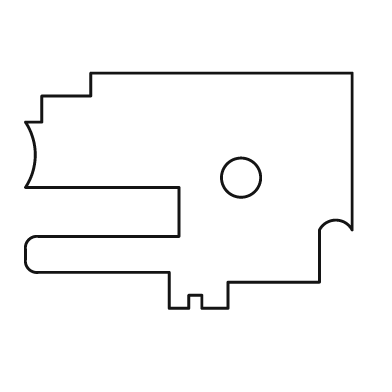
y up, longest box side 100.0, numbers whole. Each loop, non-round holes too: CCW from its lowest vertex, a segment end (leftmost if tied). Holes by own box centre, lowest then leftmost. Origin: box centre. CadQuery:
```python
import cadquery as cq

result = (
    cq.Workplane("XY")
    .moveTo(-6.0, -36.0)
    .lineTo(0.0, -36.0)
    .lineTo(0.0, -32.0)
    .lineTo(4.0, -32.0)
    .lineTo(4.0, -36.0)
    .lineTo(12.0, -36.0)
    .lineTo(12.0, -28.0)
    .lineTo(40.0, -28.0)
    .lineTo(40.0, -12.0)
    .threePointArc((45.0, -9.0), (50.0, -12.0))
    .lineTo(50.0, 36.0)
    .lineTo(-30.0, 36.0)
    .lineTo(-30.0, 29.0)
    .lineTo(-45.0, 29.0)
    .lineTo(-45.0, 21.0)
    .lineTo(-50.0, 21.0)
    .threePointArc((-47.0, 11.0), (-50.0, 1.0))
    .lineTo(-3.0, 1.0)
    .lineTo(-3.0, -14.0)
    .lineTo(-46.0, -14.0)
    .threePointArc((-49.0, -15.0), (-50.0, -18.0))
    .lineTo(-50.0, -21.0)
    .threePointArc((-49.0, -24.0), (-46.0, -25.0))
    .lineTo(-6.0, -25.0)
    .close()
    .moveTo(16.0, 4.0)
    .circle(6.0)
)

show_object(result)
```